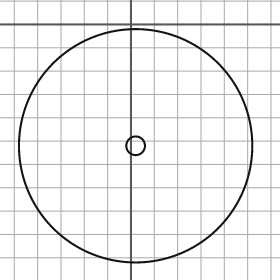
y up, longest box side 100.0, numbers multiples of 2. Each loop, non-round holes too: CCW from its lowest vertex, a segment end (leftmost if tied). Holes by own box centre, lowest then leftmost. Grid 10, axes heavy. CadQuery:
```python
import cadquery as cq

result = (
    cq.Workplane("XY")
    .moveTo(2.0, -52.0)
    .circle(50.0)
    .moveTo(2.0, -52.0)
    .circle(4.0)
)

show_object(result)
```